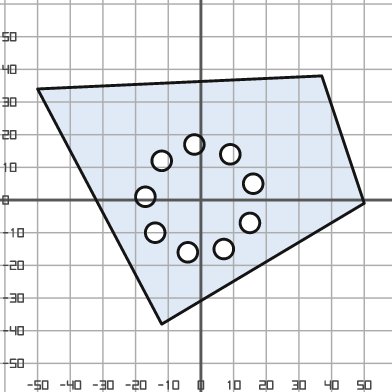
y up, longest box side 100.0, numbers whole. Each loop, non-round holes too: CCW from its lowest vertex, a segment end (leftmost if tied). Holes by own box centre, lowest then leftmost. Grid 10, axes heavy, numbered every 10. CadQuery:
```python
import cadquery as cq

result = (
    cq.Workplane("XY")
    .moveTo(-12.0, -38.0)
    .lineTo(50.0, -1.0)
    .lineTo(37.0, 38.0)
    .lineTo(-50.0, 34.0)
    .close()
    .moveTo(-4.0, -16.0)
    .circle(3.0)
    .moveTo(7.0, -15.0)
    .circle(3.0)
    .moveTo(-14.0, -10.0)
    .circle(3.0)
    .moveTo(15.0, -7.0)
    .circle(3.0)
    .moveTo(-17.0, 1.0)
    .circle(3.0)
    .moveTo(16.0, 5.0)
    .circle(3.0)
    .moveTo(-12.0, 12.0)
    .circle(3.0)
    .moveTo(9.0, 14.0)
    .circle(3.0)
    .moveTo(-2.0, 17.0)
    .circle(3.0)
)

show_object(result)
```